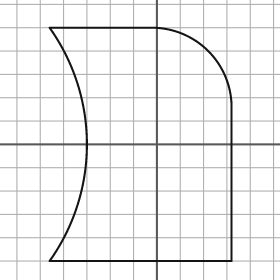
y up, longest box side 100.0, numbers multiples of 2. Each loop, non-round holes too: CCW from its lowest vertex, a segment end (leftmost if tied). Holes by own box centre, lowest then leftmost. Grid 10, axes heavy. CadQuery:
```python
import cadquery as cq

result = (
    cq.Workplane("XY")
    .moveTo(-46.0, -50.0)
    .lineTo(32.0, -50.0)
    .lineTo(32.0, 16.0)
    .threePointArc((22.0, 40.0), (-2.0, 50.0))
    .lineTo(-46.0, 50.0)
    .threePointArc((-30.0, 0.0), (-46.0, -50.0))
    .close()
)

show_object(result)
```